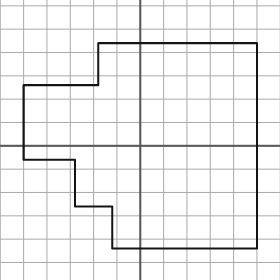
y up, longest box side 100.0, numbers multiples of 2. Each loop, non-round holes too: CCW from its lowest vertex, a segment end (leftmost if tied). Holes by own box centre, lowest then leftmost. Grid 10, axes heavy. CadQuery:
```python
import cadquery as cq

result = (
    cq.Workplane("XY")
    .moveTo(-12.0, -44.0)
    .lineTo(50.0, -44.0)
    .lineTo(50.0, 44.0)
    .lineTo(-18.0, 44.0)
    .lineTo(-18.0, 26.0)
    .lineTo(-50.0, 26.0)
    .lineTo(-50.0, -6.0)
    .lineTo(-28.0, -6.0)
    .lineTo(-28.0, -26.0)
    .lineTo(-12.0, -26.0)
    .close()
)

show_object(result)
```